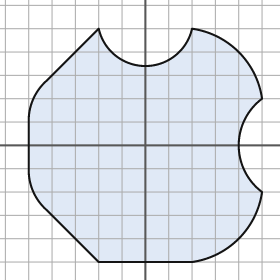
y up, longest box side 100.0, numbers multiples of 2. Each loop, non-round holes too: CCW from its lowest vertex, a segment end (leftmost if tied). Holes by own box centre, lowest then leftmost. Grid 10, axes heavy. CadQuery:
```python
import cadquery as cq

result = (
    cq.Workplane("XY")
    .moveTo(-20.0, -50.0)
    .lineTo(20.0, -50.0)
    .threePointArc((40.0, -40.0), (50.0, -20.0))
    .threePointArc((40.0, 0.0), (50.0, 20.0))
    .threePointArc((40.0, 40.0), (20.0, 50.0))
    .threePointArc((0.0, 34.0), (-20.0, 50.0))
    .lineTo(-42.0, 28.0)
    .threePointArc((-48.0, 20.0), (-50.0, 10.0))
    .lineTo(-50.0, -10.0)
    .threePointArc((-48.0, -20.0), (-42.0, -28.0))
    .close()
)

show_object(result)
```